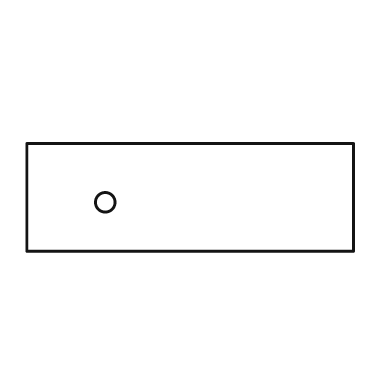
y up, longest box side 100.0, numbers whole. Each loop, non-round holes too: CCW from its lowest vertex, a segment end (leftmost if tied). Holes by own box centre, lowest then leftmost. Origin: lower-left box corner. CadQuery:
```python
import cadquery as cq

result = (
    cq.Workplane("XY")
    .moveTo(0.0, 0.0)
    .lineTo(100.0, 0.0)
    .lineTo(100.0, 33.0)
    .lineTo(0.0, 33.0)
    .close()
    .moveTo(24.0, 15.0)
    .circle(3.0)
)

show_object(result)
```